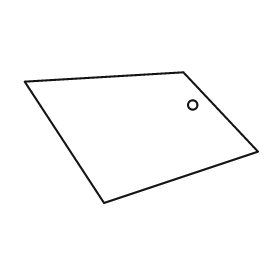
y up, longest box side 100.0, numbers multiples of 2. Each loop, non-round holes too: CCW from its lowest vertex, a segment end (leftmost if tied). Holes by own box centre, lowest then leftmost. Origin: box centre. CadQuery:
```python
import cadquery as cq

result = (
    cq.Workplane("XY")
    .moveTo(-16.0, -28.0)
    .lineTo(50.0, -6.0)
    .lineTo(18.0, 28.0)
    .lineTo(-50.0, 24.0)
    .close()
    .moveTo(22.0, 14.0)
    .circle(2.0)
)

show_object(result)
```